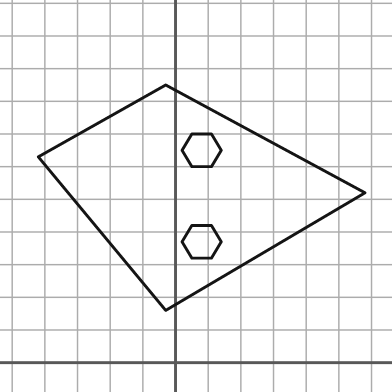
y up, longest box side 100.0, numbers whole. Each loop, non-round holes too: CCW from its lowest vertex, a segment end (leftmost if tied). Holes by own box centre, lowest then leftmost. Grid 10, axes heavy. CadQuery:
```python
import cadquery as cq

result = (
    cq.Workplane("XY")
    .moveTo(-3.0, 16.0)
    .lineTo(58.0, 52.0)
    .lineTo(-3.0, 85.0)
    .lineTo(-42.0, 63.0)
    .close()
    .moveTo(5.0, 32.0)
    .lineTo(11.0, 32.0)
    .lineTo(14.0, 37.0)
    .lineTo(11.0, 42.0)
    .lineTo(5.0, 42.0)
    .lineTo(2.0, 37.0)
    .close()
    .moveTo(5.0, 60.0)
    .lineTo(11.0, 60.0)
    .lineTo(14.0, 65.0)
    .lineTo(11.0, 70.0)
    .lineTo(5.0, 70.0)
    .lineTo(2.0, 65.0)
    .close()
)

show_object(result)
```